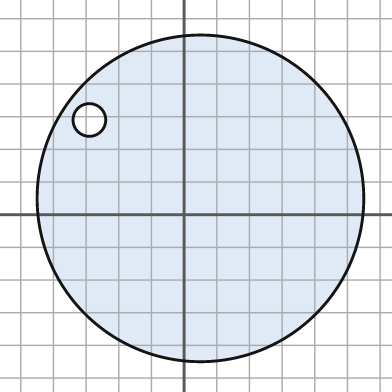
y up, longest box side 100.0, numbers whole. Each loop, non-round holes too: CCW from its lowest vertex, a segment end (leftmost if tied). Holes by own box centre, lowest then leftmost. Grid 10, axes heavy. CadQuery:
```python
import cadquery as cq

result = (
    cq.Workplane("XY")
    .moveTo(5.0, 5.0)
    .circle(50.0)
    .moveTo(-29.0, 29.0)
    .circle(5.0)
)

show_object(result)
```